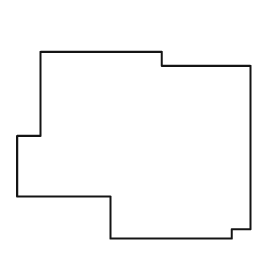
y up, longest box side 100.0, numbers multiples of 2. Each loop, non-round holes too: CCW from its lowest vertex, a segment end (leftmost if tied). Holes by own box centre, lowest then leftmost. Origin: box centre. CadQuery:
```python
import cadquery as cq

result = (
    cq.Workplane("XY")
    .moveTo(-10.0, -40.0)
    .lineTo(42.0, -40.0)
    .lineTo(42.0, -36.0)
    .lineTo(50.0, -36.0)
    .lineTo(50.0, 34.0)
    .lineTo(12.0, 34.0)
    .lineTo(12.0, 40.0)
    .lineTo(-40.0, 40.0)
    .lineTo(-40.0, 4.0)
    .lineTo(-50.0, 4.0)
    .lineTo(-50.0, -22.0)
    .lineTo(-10.0, -22.0)
    .close()
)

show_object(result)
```